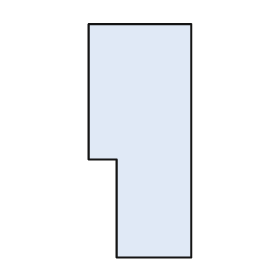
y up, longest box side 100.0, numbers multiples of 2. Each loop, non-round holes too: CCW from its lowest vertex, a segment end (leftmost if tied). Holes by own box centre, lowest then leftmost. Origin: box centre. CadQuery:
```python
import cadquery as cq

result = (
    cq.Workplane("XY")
    .moveTo(-10.0, -50.0)
    .lineTo(22.0, -50.0)
    .lineTo(22.0, 50.0)
    .lineTo(-22.0, 50.0)
    .lineTo(-22.0, -8.0)
    .lineTo(-10.0, -8.0)
    .close()
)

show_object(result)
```